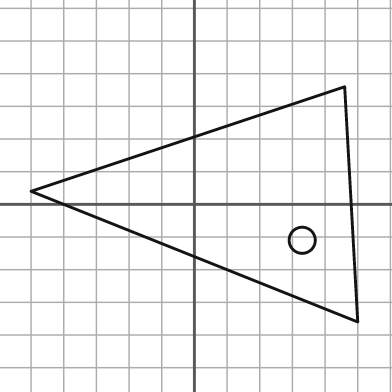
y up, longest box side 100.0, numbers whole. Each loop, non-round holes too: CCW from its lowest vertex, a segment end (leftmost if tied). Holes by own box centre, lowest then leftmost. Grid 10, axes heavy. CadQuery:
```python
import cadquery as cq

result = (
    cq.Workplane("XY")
    .moveTo(50.0, -36.0)
    .lineTo(46.0, 36.0)
    .lineTo(-50.0, 4.0)
    .close()
    .moveTo(33.0, -11.0)
    .circle(4.0)
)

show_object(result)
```